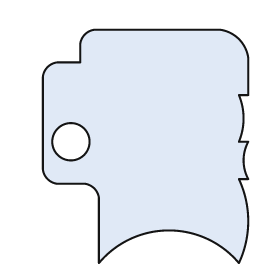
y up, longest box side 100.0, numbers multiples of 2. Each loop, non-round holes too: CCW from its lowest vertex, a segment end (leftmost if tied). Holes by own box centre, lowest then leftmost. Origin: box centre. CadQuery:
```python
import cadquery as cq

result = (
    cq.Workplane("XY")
    .moveTo(-20.0, -50.0)
    .threePointArc((10.0, -36.0), (40.0, -50.0))
    .threePointArc((44.0, -32.0), (40.0, -14.0))
    .lineTo(44.0, -14.0)
    .threePointArc((42.0, -6.0), (44.0, 2.0))
    .lineTo(40.0, 2.0)
    .threePointArc((42.0, 12.0), (40.0, 22.0))
    .lineTo(44.0, 22.0)
    .lineTo(44.0, 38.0)
    .threePointArc((40.0, 46.0), (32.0, 50.0))
    .lineTo(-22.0, 50.0)
    .threePointArc((-26.0, 48.0), (-28.0, 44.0))
    .lineTo(-28.0, 36.0)
    .lineTo(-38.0, 36.0)
    .threePointArc((-42.0, 34.0), (-44.0, 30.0))
    .lineTo(-44.0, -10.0)
    .threePointArc((-42.0, -14.0), (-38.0, -16.0))
    .lineTo(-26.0, -16.0)
    .threePointArc((-22.0, -18.0), (-20.0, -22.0))
    .close()
    .moveTo(-32.0, 2.0)
    .circle(8.0)
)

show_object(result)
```